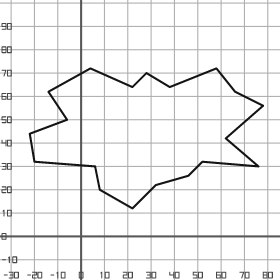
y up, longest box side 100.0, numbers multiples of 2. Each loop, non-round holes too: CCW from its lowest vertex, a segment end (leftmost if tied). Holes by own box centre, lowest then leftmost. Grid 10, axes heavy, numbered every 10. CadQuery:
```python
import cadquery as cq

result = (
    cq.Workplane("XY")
    .moveTo(22.0, 12.0)
    .lineTo(32.0, 22.0)
    .lineTo(46.0, 26.0)
    .lineTo(52.0, 32.0)
    .lineTo(76.0, 30.0)
    .lineTo(62.0, 42.0)
    .lineTo(78.0, 56.0)
    .lineTo(66.0, 62.0)
    .lineTo(58.0, 72.0)
    .lineTo(38.0, 64.0)
    .lineTo(28.0, 70.0)
    .lineTo(22.0, 64.0)
    .lineTo(4.0, 72.0)
    .lineTo(-14.0, 62.0)
    .lineTo(-6.0, 50.0)
    .lineTo(-22.0, 44.0)
    .lineTo(-20.0, 32.0)
    .lineTo(6.0, 30.0)
    .lineTo(8.0, 20.0)
    .close()
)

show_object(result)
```